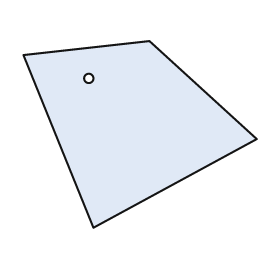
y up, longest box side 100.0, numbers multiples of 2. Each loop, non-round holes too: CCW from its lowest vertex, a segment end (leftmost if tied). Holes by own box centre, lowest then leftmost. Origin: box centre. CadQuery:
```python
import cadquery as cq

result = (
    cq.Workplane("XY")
    .moveTo(-20.0, -40.0)
    .lineTo(50.0, -2.0)
    .lineTo(4.0, 40.0)
    .lineTo(-50.0, 34.0)
    .close()
    .moveTo(-22.0, 24.0)
    .circle(2.0)
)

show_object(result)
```